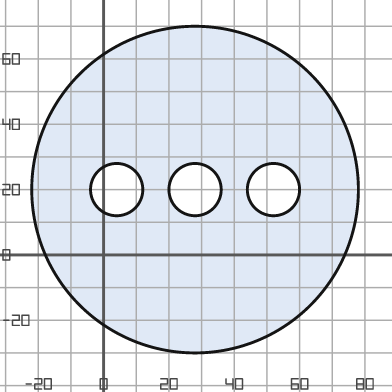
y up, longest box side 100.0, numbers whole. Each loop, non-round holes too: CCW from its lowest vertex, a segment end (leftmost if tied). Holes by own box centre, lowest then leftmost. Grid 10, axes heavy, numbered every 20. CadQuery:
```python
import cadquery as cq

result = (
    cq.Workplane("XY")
    .moveTo(28.0, 20.0)
    .circle(50.0)
    .moveTo(4.0, 20.0)
    .circle(8.0)
    .moveTo(28.0, 20.0)
    .circle(8.0)
    .moveTo(52.0, 20.0)
    .circle(8.0)
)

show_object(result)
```